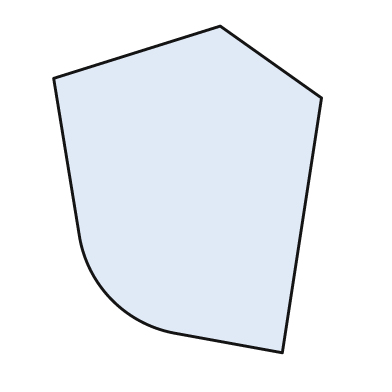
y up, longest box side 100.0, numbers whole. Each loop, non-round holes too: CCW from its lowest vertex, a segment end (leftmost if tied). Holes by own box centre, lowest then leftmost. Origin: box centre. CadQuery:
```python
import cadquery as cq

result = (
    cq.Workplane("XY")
    .moveTo(29.0, -50.0)
    .lineTo(41.0, 28.0)
    .lineTo(10.0, 50.0)
    .lineTo(-41.0, 34.0)
    .lineTo(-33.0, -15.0)
    .threePointArc((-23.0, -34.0), (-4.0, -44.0))
    .close()
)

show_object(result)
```